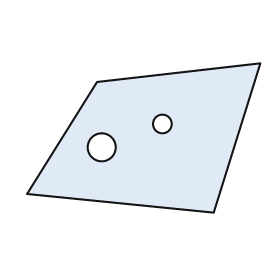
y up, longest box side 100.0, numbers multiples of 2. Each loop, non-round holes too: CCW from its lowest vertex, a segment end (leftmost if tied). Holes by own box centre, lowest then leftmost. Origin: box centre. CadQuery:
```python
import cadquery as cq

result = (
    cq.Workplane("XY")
    .moveTo(30.0, -32.0)
    .lineTo(50.0, 32.0)
    .lineTo(-20.0, 24.0)
    .lineTo(-50.0, -24.0)
    .close()
    .moveTo(-18.0, -4.0)
    .circle(6.0)
    .moveTo(8.0, 6.0)
    .circle(4.0)
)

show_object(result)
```